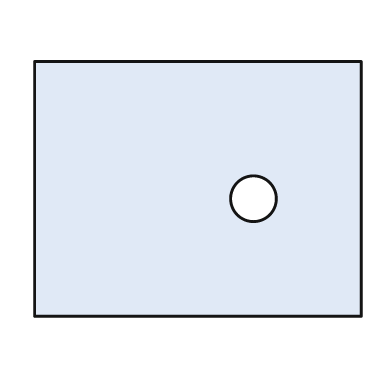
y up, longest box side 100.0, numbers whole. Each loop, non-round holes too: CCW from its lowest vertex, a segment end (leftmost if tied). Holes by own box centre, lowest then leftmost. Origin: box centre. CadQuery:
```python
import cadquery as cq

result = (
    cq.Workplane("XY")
    .moveTo(-50.0, -39.0)
    .lineTo(50.0, -39.0)
    .lineTo(50.0, 39.0)
    .lineTo(-50.0, 39.0)
    .close()
    .moveTo(17.0, -3.0)
    .circle(7.0)
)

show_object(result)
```